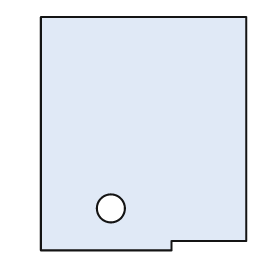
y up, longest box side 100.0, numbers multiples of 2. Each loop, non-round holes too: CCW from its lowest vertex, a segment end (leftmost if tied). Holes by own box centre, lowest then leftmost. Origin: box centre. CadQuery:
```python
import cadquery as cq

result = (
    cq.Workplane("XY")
    .moveTo(-44.0, -50.0)
    .lineTo(12.0, -50.0)
    .lineTo(12.0, -46.0)
    .lineTo(44.0, -46.0)
    .lineTo(44.0, 50.0)
    .lineTo(-44.0, 50.0)
    .close()
    .moveTo(-14.0, -32.0)
    .circle(6.0)
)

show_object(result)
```